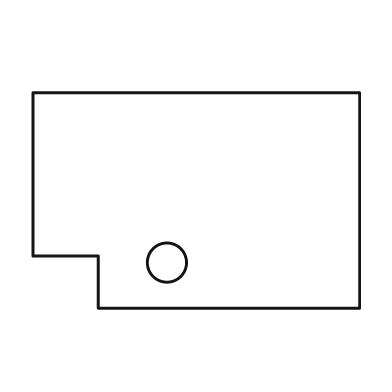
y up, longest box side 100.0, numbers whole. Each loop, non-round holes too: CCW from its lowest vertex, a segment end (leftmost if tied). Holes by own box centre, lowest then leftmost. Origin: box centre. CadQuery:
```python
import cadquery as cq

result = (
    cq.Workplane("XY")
    .moveTo(-30.0, -33.0)
    .lineTo(50.0, -33.0)
    .lineTo(50.0, 33.0)
    .lineTo(-50.0, 33.0)
    .lineTo(-50.0, -17.0)
    .lineTo(-30.0, -17.0)
    .close()
    .moveTo(-9.0, -19.0)
    .circle(6.0)
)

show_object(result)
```